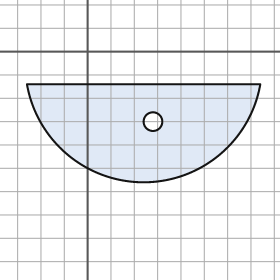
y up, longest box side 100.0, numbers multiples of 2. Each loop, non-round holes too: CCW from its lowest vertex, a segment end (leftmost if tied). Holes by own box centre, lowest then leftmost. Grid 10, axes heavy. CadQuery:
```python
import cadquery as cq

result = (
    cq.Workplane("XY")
    .moveTo(-26.0, -14.0)
    .threePointArc((24.0, -56.0), (74.0, -14.0))
    .close()
    .moveTo(28.0, -30.0)
    .circle(4.0)
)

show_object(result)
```